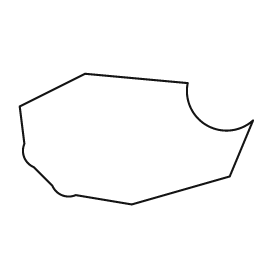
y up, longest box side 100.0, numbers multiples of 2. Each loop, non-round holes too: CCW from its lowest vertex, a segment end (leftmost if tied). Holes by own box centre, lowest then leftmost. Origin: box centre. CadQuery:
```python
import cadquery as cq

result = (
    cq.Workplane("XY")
    .moveTo(-2.0, -28.0)
    .lineTo(40.0, -16.0)
    .lineTo(50.0, 8.0)
    .threePointArc((30.0, 6.0), (22.0, 24.0))
    .lineTo(-22.0, 28.0)
    .lineTo(-50.0, 14.0)
    .lineTo(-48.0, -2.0)
    .threePointArc((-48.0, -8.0), (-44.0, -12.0))
    .lineTo(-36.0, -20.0)
    .threePointArc((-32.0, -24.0), (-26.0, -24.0))
    .close()
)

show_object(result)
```